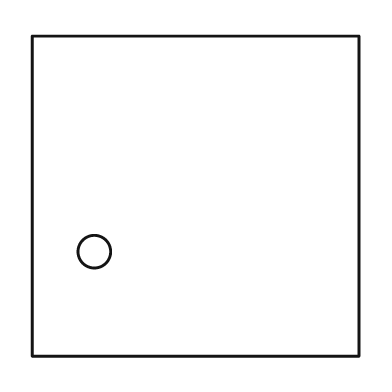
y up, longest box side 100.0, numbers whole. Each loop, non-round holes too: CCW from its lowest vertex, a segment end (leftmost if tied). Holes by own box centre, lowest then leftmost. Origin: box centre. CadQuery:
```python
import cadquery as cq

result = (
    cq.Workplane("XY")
    .moveTo(-50.0, -49.0)
    .lineTo(50.0, -49.0)
    .lineTo(50.0, 49.0)
    .lineTo(-50.0, 49.0)
    .close()
    .moveTo(-31.0, -17.0)
    .circle(5.0)
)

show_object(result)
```